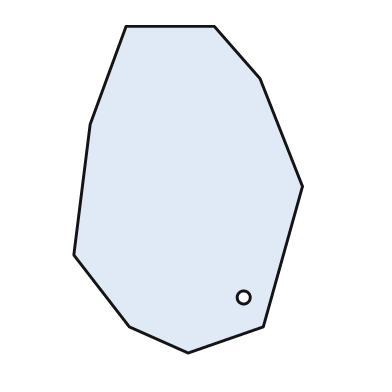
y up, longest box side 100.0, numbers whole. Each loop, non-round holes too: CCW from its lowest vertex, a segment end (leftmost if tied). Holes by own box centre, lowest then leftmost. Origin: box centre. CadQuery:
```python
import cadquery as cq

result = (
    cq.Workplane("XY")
    .moveTo(0.0, -50.0)
    .lineTo(23.0, -42.0)
    .lineTo(35.0, 1.0)
    .lineTo(22.0, 34.0)
    .lineTo(8.0, 50.0)
    .lineTo(-19.0, 50.0)
    .lineTo(-30.0, 20.0)
    .lineTo(-35.0, -20.0)
    .lineTo(-18.0, -42.0)
    .close()
    .moveTo(17.0, -33.0)
    .circle(2.0)
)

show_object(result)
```